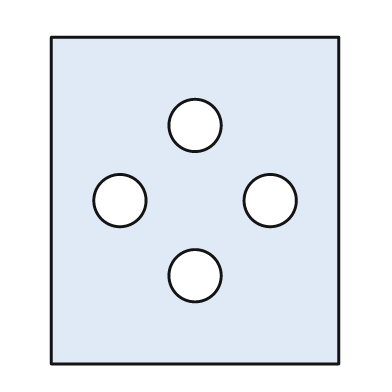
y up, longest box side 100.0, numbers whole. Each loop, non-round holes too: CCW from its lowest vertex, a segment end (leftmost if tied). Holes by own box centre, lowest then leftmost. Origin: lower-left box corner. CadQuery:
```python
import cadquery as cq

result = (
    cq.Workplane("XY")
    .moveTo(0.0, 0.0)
    .lineTo(88.0, 0.0)
    .lineTo(88.0, 100.0)
    .lineTo(0.0, 100.0)
    .close()
    .moveTo(44.0, 27.0)
    .circle(8.0)
    .moveTo(21.0, 50.0)
    .circle(8.0)
    .moveTo(67.0, 50.0)
    .circle(8.0)
    .moveTo(44.0, 73.0)
    .circle(8.0)
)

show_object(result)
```